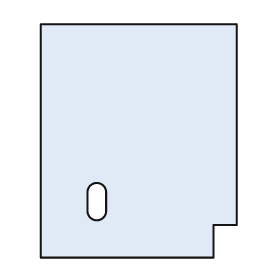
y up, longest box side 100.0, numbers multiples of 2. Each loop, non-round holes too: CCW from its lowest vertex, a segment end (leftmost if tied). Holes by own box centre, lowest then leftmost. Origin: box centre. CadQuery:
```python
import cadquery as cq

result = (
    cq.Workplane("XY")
    .moveTo(-42.0, -50.0)
    .lineTo(32.0, -50.0)
    .lineTo(32.0, -36.0)
    .lineTo(42.0, -36.0)
    .lineTo(42.0, 50.0)
    .lineTo(-42.0, 50.0)
    .close()
    .moveTo(-22.0, -30.0)
    .threePointArc((-18.0, -34.0), (-14.0, -30.0))
    .lineTo(-14.0, -22.0)
    .threePointArc((-18.0, -18.0), (-22.0, -22.0))
    .close()
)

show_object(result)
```